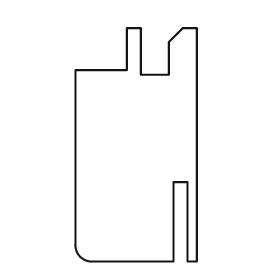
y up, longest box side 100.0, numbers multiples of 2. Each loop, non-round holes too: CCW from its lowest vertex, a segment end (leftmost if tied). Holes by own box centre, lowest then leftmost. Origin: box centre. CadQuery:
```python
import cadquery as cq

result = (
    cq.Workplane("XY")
    .moveTo(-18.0, -50.0)
    .lineTo(16.0, -50.0)
    .lineTo(16.0, -16.0)
    .lineTo(22.0, -16.0)
    .lineTo(22.0, -50.0)
    .lineTo(26.0, -50.0)
    .lineTo(26.0, 50.0)
    .lineTo(20.0, 50.0)
    .lineTo(14.0, 44.0)
    .lineTo(14.0, 30.0)
    .lineTo(2.0, 30.0)
    .lineTo(2.0, 50.0)
    .lineTo(-4.0, 50.0)
    .lineTo(-4.0, 32.0)
    .lineTo(-26.0, 32.0)
    .lineTo(-26.0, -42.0)
    .threePointArc((-24.0, -48.0), (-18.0, -50.0))
    .close()
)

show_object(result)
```